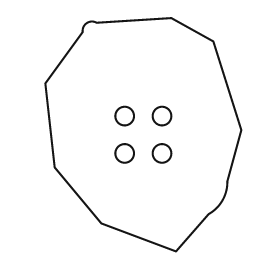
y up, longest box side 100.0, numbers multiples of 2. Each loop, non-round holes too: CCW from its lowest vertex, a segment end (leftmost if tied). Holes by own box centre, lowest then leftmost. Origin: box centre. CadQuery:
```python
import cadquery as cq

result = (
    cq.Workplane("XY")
    .moveTo(14.0, -50.0)
    .lineTo(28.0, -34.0)
    .threePointArc((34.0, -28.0), (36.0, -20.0))
    .lineTo(42.0, 2.0)
    .lineTo(30.0, 40.0)
    .lineTo(12.0, 50.0)
    .lineTo(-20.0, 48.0)
    .threePointArc((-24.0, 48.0), (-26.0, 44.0))
    .lineTo(-42.0, 22.0)
    .lineTo(-38.0, -14.0)
    .lineTo(-18.0, -38.0)
    .close()
    .moveTo(-8.0, -8.0)
    .circle(4.0)
    .moveTo(8.0, -8.0)
    .circle(4.0)
    .moveTo(-8.0, 8.0)
    .circle(4.0)
    .moveTo(8.0, 8.0)
    .circle(4.0)
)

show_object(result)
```